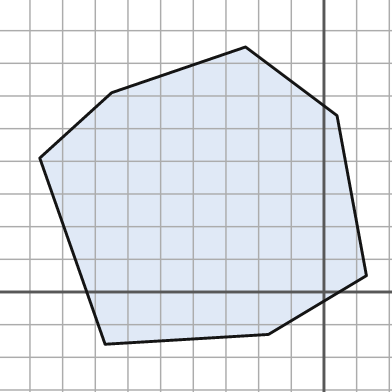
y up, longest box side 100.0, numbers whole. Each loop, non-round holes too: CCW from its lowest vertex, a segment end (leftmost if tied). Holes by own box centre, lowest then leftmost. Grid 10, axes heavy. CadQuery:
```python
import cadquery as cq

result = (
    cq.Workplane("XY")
    .moveTo(-67.0, -16.0)
    .lineTo(-17.0, -13.0)
    .lineTo(13.0, 5.0)
    .lineTo(4.0, 54.0)
    .lineTo(-24.0, 75.0)
    .lineTo(-65.0, 61.0)
    .lineTo(-87.0, 41.0)
    .close()
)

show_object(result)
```